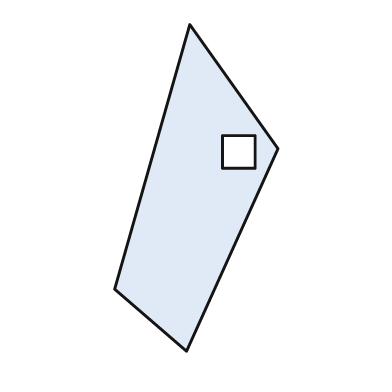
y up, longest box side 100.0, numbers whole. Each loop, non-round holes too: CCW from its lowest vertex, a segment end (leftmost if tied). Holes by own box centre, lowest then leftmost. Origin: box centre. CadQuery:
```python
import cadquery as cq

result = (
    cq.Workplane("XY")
    .moveTo(-3.0, -50.0)
    .lineTo(25.0, 12.0)
    .lineTo(-2.0, 50.0)
    .lineTo(-25.0, -31.0)
    .close()
    .moveTo(8.0, 6.0)
    .lineTo(18.0, 6.0)
    .lineTo(18.0, 16.0)
    .lineTo(8.0, 16.0)
    .close()
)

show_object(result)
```